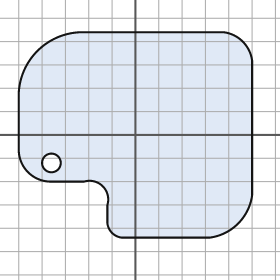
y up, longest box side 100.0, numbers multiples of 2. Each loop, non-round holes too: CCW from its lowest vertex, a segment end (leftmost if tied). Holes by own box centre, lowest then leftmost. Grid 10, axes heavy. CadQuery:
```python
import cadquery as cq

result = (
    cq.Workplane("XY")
    .moveTo(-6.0, -44.0)
    .lineTo(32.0, -44.0)
    .threePointArc((44.0, -38.0), (50.0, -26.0))
    .lineTo(50.0, 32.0)
    .threePointArc((46.0, 40.0), (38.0, 44.0))
    .lineTo(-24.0, 44.0)
    .threePointArc((-42.0, 36.0), (-50.0, 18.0))
    .lineTo(-50.0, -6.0)
    .threePointArc((-46.0, -16.0), (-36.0, -20.0))
    .lineTo(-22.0, -20.0)
    .threePointArc((-14.0, -22.0), (-12.0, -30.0))
    .lineTo(-12.0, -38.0)
    .threePointArc((-10.0, -42.0), (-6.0, -44.0))
    .close()
    .moveTo(-36.0, -12.0)
    .circle(4.0)
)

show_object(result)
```